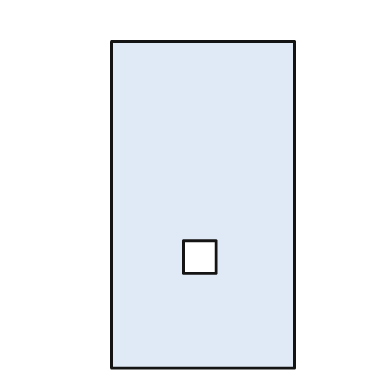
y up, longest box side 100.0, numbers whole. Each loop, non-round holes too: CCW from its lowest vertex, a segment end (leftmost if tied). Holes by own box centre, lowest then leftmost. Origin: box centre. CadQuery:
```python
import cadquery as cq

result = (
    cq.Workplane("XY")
    .moveTo(-28.0, -50.0)
    .lineTo(28.0, -50.0)
    .lineTo(28.0, 50.0)
    .lineTo(-28.0, 50.0)
    .close()
    .moveTo(-6.0, -21.0)
    .lineTo(4.0, -21.0)
    .lineTo(4.0, -11.0)
    .lineTo(-6.0, -11.0)
    .close()
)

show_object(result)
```